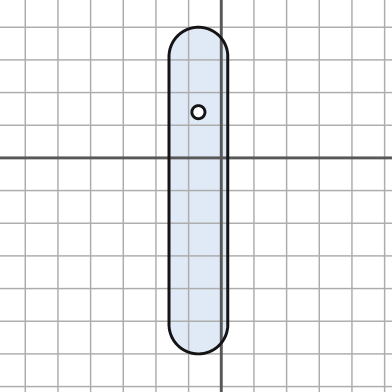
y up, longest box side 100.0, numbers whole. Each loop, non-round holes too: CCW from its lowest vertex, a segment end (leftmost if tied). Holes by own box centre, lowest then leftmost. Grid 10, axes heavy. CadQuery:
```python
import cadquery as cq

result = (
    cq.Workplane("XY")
    .moveTo(-16.0, -51.0)
    .threePointArc((-7.0, -60.0), (2.0, -51.0))
    .lineTo(2.0, 31.0)
    .threePointArc((-7.0, 40.0), (-16.0, 31.0))
    .close()
    .moveTo(-7.0, 14.0)
    .circle(2.0)
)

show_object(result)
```